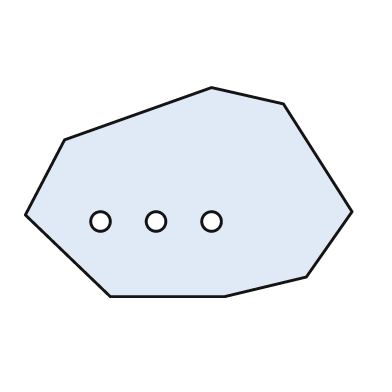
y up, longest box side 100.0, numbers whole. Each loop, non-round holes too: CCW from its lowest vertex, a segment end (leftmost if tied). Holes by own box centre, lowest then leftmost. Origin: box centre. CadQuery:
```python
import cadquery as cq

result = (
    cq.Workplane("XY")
    .moveTo(-24.0, -32.0)
    .lineTo(11.0, -32.0)
    .lineTo(36.0, -26.0)
    .lineTo(50.0, -6.0)
    .lineTo(29.0, 27.0)
    .lineTo(7.0, 32.0)
    .lineTo(-38.0, 16.0)
    .lineTo(-50.0, -7.0)
    .close()
    .moveTo(-27.0, -9.0)
    .circle(3.0)
    .moveTo(-10.0, -9.0)
    .circle(3.0)
    .moveTo(7.0, -9.0)
    .circle(3.0)
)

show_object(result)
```